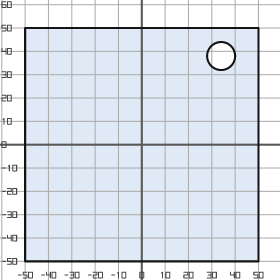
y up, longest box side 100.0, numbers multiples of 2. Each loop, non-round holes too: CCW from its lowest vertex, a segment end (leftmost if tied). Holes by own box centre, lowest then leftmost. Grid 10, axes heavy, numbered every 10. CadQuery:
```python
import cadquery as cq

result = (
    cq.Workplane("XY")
    .moveTo(-50.0, -50.0)
    .lineTo(50.0, -50.0)
    .lineTo(50.0, 50.0)
    .lineTo(-50.0, 50.0)
    .close()
    .moveTo(34.0, 38.0)
    .circle(6.0)
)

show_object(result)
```